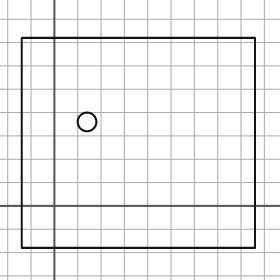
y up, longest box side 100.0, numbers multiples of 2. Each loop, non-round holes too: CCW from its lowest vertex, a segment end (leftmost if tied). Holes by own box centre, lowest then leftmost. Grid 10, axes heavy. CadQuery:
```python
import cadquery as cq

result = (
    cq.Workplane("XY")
    .moveTo(-14.0, -18.0)
    .lineTo(86.0, -18.0)
    .lineTo(86.0, 72.0)
    .lineTo(-14.0, 72.0)
    .close()
    .moveTo(14.0, 36.0)
    .circle(4.0)
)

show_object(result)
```